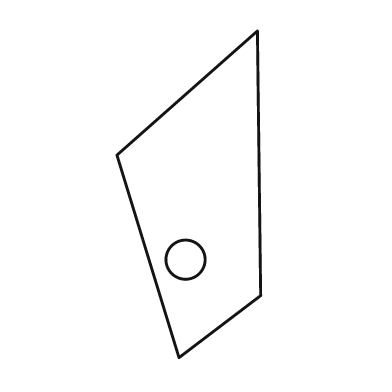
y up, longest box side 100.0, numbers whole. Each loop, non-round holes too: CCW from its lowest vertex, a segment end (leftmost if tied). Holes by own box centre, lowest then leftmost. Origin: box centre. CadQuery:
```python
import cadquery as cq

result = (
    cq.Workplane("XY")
    .moveTo(-3.0, -50.0)
    .lineTo(22.0, -31.0)
    .lineTo(21.0, 50.0)
    .lineTo(-22.0, 12.0)
    .close()
    .moveTo(-1.0, -20.0)
    .circle(6.0)
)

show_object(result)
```